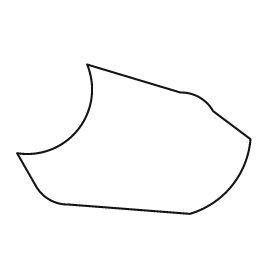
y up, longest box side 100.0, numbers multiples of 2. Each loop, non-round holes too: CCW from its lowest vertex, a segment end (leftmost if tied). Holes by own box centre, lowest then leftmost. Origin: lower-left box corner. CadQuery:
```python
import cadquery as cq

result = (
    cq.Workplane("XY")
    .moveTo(74.0, 0.0)
    .threePointArc((92.0, 12.0), (100.0, 32.0))
    .lineTo(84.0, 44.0)
    .threePointArc((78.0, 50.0), (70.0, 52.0))
    .lineTo(30.0, 64.0)
    .threePointArc((26.0, 36.0), (0.0, 26.0))
    .lineTo(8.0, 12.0)
    .threePointArc((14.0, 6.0), (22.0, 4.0))
    .close()
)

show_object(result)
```